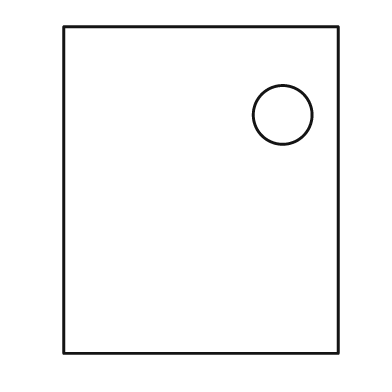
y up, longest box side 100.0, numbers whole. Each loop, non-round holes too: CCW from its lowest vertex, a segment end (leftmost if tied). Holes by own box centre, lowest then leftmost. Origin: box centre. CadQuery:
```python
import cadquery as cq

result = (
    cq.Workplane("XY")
    .moveTo(-42.0, -50.0)
    .lineTo(42.0, -50.0)
    .lineTo(42.0, 50.0)
    .lineTo(-42.0, 50.0)
    .close()
    .moveTo(25.0, 23.0)
    .circle(9.0)
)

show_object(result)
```